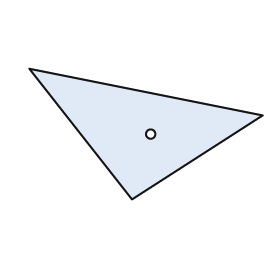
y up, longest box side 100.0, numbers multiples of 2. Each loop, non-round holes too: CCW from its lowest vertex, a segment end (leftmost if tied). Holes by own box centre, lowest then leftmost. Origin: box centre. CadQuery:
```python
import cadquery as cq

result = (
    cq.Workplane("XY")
    .moveTo(-6.0, -28.0)
    .lineTo(50.0, 8.0)
    .lineTo(-50.0, 28.0)
    .close()
    .moveTo(2.0, 0.0)
    .circle(2.0)
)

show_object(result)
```